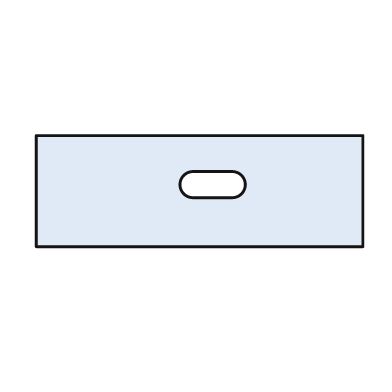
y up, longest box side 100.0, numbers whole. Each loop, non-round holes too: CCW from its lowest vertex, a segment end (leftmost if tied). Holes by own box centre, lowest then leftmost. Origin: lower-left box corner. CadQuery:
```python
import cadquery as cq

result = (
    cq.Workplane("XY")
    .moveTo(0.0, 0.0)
    .lineTo(100.0, 0.0)
    .lineTo(100.0, 34.0)
    .lineTo(0.0, 34.0)
    .close()
    .moveTo(48.0, 15.0)
    .lineTo(60.0, 15.0)
    .threePointArc((64.0, 19.0), (60.0, 23.0))
    .lineTo(48.0, 23.0)
    .threePointArc((44.0, 19.0), (48.0, 15.0))
    .close()
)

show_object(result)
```